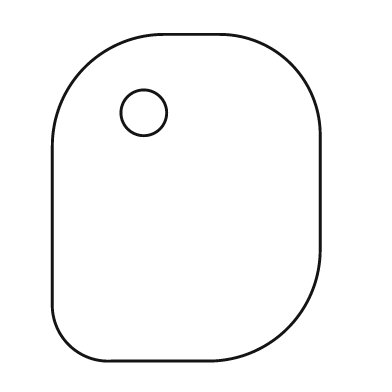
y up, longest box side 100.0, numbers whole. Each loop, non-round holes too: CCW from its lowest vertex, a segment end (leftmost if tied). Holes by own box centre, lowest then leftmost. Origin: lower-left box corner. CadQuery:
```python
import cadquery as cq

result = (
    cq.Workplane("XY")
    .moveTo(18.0, 0.0)
    .lineTo(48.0, 0.0)
    .threePointArc((72.0, 10.0), (82.0, 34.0))
    .lineTo(82.0, 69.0)
    .threePointArc((73.0, 91.0), (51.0, 100.0))
    .lineTo(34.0, 100.0)
    .threePointArc((10.0, 90.0), (0.0, 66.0))
    .lineTo(0.0, 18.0)
    .threePointArc((5.0, 5.0), (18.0, 0.0))
    .close()
    .moveTo(28.0, 76.0)
    .circle(7.0)
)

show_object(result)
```